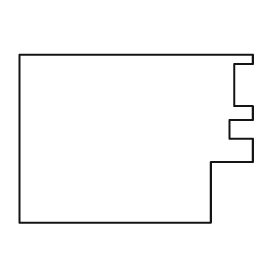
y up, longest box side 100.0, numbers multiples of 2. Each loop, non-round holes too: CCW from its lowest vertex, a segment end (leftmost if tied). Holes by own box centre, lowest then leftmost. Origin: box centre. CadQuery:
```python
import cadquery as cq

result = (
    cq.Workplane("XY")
    .moveTo(-50.0, -36.0)
    .lineTo(32.0, -36.0)
    .lineTo(32.0, -10.0)
    .lineTo(50.0, -10.0)
    .lineTo(50.0, 0.0)
    .lineTo(40.0, 0.0)
    .lineTo(40.0, 8.0)
    .lineTo(50.0, 8.0)
    .lineTo(50.0, 14.0)
    .lineTo(42.0, 14.0)
    .lineTo(42.0, 32.0)
    .lineTo(50.0, 32.0)
    .lineTo(50.0, 36.0)
    .lineTo(-50.0, 36.0)
    .close()
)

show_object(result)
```